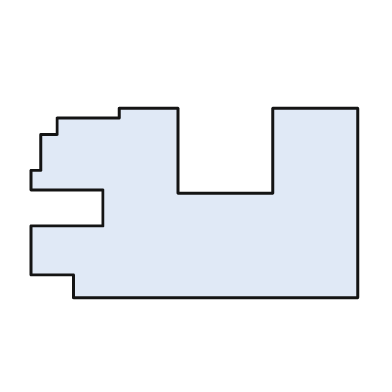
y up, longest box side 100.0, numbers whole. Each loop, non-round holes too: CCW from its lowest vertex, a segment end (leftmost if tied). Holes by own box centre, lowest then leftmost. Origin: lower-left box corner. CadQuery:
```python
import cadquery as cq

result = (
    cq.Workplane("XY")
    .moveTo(13.0, 0.0)
    .lineTo(100.0, 0.0)
    .lineTo(100.0, 58.0)
    .lineTo(74.0, 58.0)
    .lineTo(74.0, 32.0)
    .lineTo(45.0, 32.0)
    .lineTo(45.0, 58.0)
    .lineTo(27.0, 58.0)
    .lineTo(27.0, 55.0)
    .lineTo(8.0, 55.0)
    .lineTo(8.0, 50.0)
    .lineTo(3.0, 50.0)
    .lineTo(3.0, 39.0)
    .lineTo(0.0, 39.0)
    .lineTo(0.0, 33.0)
    .lineTo(22.0, 33.0)
    .lineTo(22.0, 22.0)
    .lineTo(0.0, 22.0)
    .lineTo(0.0, 7.0)
    .lineTo(13.0, 7.0)
    .close()
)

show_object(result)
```